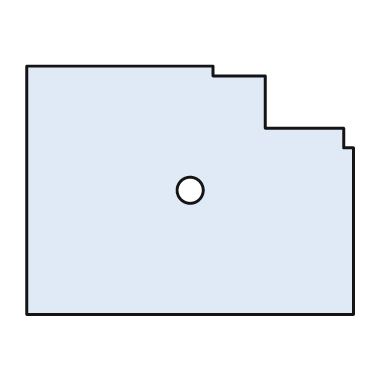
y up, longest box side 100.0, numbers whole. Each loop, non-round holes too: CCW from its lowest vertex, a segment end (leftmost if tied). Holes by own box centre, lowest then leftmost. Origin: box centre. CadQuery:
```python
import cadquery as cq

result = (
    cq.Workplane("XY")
    .moveTo(-50.0, -38.0)
    .lineTo(50.0, -38.0)
    .lineTo(50.0, 13.0)
    .lineTo(47.0, 13.0)
    .lineTo(47.0, 19.0)
    .lineTo(23.0, 19.0)
    .lineTo(23.0, 35.0)
    .lineTo(7.0, 35.0)
    .lineTo(7.0, 38.0)
    .lineTo(-50.0, 38.0)
    .close()
    .moveTo(0.0, 0.0)
    .circle(4.0)
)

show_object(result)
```